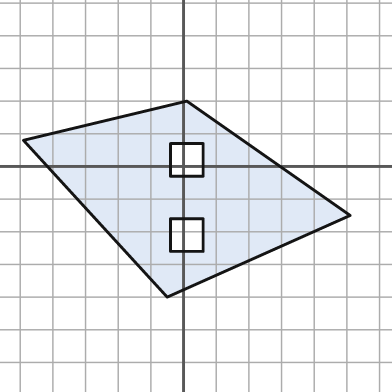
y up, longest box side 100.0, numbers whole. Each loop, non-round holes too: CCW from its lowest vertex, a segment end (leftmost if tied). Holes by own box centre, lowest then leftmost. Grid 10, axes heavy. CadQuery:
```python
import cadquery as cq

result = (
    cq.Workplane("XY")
    .moveTo(-5.0, -40.0)
    .lineTo(51.0, -15.0)
    .lineTo(1.0, 20.0)
    .lineTo(-49.0, 8.0)
    .close()
    .moveTo(-4.0, -26.0)
    .lineTo(6.0, -26.0)
    .lineTo(6.0, -16.0)
    .lineTo(-4.0, -16.0)
    .close()
    .moveTo(-4.0, -3.0)
    .lineTo(6.0, -3.0)
    .lineTo(6.0, 7.0)
    .lineTo(-4.0, 7.0)
    .close()
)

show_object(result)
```